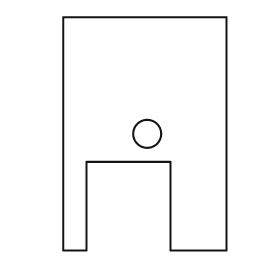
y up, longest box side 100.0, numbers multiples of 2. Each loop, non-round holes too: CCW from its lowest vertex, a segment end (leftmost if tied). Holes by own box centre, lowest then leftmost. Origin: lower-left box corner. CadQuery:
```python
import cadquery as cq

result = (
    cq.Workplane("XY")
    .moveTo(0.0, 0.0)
    .lineTo(10.0, 0.0)
    .lineTo(10.0, 38.0)
    .lineTo(46.0, 38.0)
    .lineTo(46.0, 0.0)
    .lineTo(70.0, 0.0)
    .lineTo(70.0, 100.0)
    .lineTo(0.0, 100.0)
    .close()
    .moveTo(36.0, 50.0)
    .circle(6.0)
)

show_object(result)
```